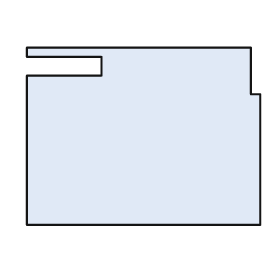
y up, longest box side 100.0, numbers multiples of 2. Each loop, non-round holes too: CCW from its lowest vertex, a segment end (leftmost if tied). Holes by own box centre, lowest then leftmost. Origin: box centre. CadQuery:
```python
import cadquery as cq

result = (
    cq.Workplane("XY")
    .moveTo(-50.0, -38.0)
    .lineTo(50.0, -38.0)
    .lineTo(50.0, 18.0)
    .lineTo(46.0, 18.0)
    .lineTo(46.0, 38.0)
    .lineTo(-50.0, 38.0)
    .lineTo(-50.0, 34.0)
    .lineTo(-18.0, 34.0)
    .lineTo(-18.0, 26.0)
    .lineTo(-50.0, 26.0)
    .close()
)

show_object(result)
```